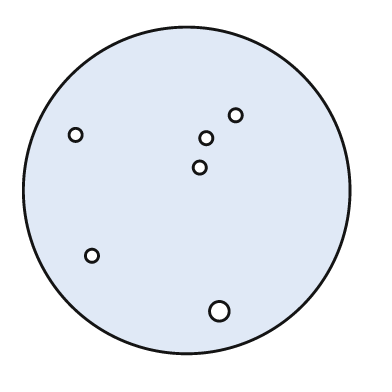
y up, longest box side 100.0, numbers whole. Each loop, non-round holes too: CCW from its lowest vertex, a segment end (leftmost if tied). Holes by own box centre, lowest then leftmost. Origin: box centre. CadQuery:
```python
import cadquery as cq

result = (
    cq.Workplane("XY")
    .moveTo(0.0, 0.0)
    .circle(50.0)
    .moveTo(10.0, -37.0)
    .circle(3.0)
    .moveTo(-29.0, -20.0)
    .circle(2.0)
    .moveTo(4.0, 7.0)
    .circle(2.0)
    .moveTo(6.0, 16.0)
    .circle(2.0)
    .moveTo(-34.0, 17.0)
    .circle(2.0)
    .moveTo(15.0, 23.0)
    .circle(2.0)
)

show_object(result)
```